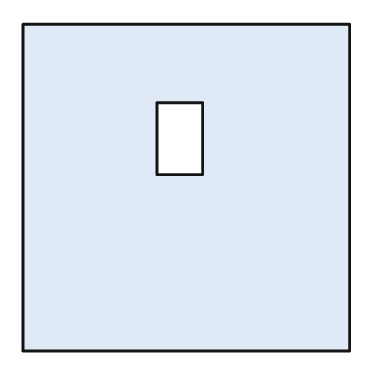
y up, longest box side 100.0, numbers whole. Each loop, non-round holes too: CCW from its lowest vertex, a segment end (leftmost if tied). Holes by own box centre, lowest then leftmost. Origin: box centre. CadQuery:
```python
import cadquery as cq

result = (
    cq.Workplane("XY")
    .moveTo(-50.0, -50.0)
    .lineTo(50.0, -50.0)
    .lineTo(50.0, 50.0)
    .lineTo(-50.0, 50.0)
    .close()
    .moveTo(-9.0, 4.0)
    .lineTo(5.0, 4.0)
    .lineTo(5.0, 26.0)
    .lineTo(-9.0, 26.0)
    .close()
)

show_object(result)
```